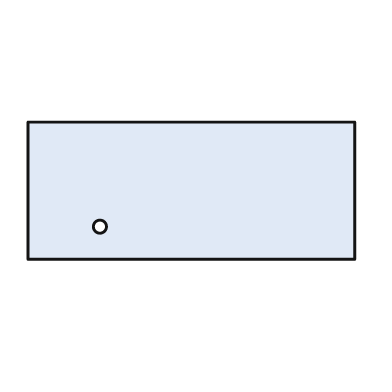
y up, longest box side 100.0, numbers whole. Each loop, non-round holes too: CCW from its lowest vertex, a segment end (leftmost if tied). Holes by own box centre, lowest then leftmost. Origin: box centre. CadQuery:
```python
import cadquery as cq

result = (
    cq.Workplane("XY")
    .moveTo(-50.0, -21.0)
    .lineTo(50.0, -21.0)
    .lineTo(50.0, 21.0)
    .lineTo(-50.0, 21.0)
    .close()
    .moveTo(-28.0, -11.0)
    .circle(2.0)
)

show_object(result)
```